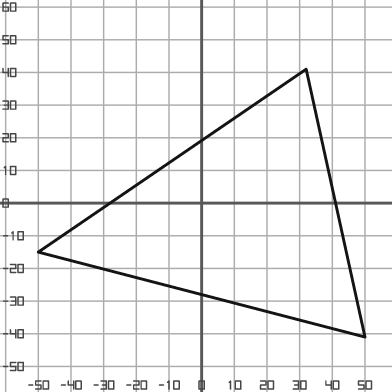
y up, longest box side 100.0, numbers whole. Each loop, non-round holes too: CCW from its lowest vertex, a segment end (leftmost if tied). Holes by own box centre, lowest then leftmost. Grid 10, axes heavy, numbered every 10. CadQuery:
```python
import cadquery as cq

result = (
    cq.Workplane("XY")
    .moveTo(50.0, -41.0)
    .lineTo(32.0, 41.0)
    .lineTo(-50.0, -15.0)
    .close()
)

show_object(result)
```